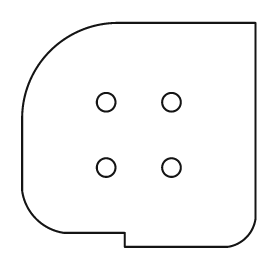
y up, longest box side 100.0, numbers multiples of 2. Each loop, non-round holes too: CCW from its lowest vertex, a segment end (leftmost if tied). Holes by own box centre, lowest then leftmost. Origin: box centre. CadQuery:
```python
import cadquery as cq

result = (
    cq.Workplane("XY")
    .moveTo(-6.0, -48.0)
    .lineTo(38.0, -48.0)
    .threePointArc((46.0, -44.0), (50.0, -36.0))
    .lineTo(50.0, 48.0)
    .lineTo(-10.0, 48.0)
    .threePointArc((-38.0, 36.0), (-50.0, 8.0))
    .lineTo(-50.0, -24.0)
    .threePointArc((-44.0, -36.0), (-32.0, -42.0))
    .lineTo(-6.0, -42.0)
    .close()
    .moveTo(-14.0, -14.0)
    .circle(4.0)
    .moveTo(14.0, -14.0)
    .circle(4.0)
    .moveTo(-14.0, 14.0)
    .circle(4.0)
    .moveTo(14.0, 14.0)
    .circle(4.0)
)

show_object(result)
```